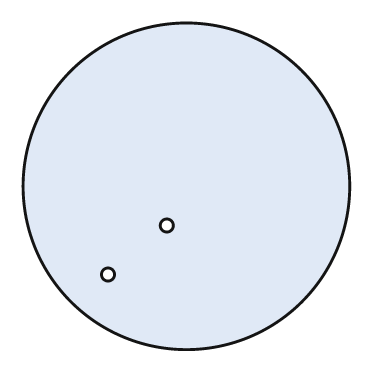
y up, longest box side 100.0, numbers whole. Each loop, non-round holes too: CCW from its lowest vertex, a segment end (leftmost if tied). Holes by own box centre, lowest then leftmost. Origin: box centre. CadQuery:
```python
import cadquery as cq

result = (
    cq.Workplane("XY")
    .moveTo(0.0, 0.0)
    .circle(50.0)
    .moveTo(-24.0, -27.0)
    .circle(2.0)
    .moveTo(-6.0, -12.0)
    .circle(2.0)
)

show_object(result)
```